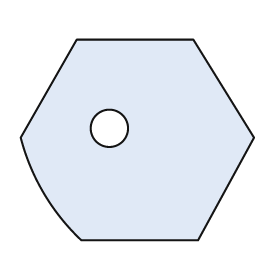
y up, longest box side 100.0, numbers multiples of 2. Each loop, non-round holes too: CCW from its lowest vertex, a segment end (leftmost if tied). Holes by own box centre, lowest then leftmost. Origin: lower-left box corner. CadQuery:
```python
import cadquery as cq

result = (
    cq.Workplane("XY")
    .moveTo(26.0, 0.0)
    .lineTo(76.0, 0.0)
    .lineTo(100.0, 44.0)
    .lineTo(74.0, 86.0)
    .lineTo(24.0, 86.0)
    .lineTo(0.0, 44.0)
    .threePointArc((10.0, 20.0), (26.0, 0.0))
    .close()
    .moveTo(38.0, 48.0)
    .circle(8.0)
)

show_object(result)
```